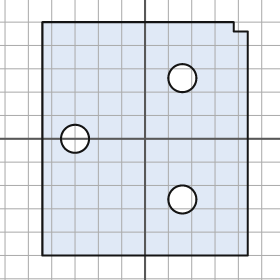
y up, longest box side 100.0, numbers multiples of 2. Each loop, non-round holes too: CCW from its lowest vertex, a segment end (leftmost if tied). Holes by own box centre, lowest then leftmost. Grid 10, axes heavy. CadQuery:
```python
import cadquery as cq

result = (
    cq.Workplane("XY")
    .moveTo(-44.0, -50.0)
    .lineTo(44.0, -50.0)
    .lineTo(44.0, 46.0)
    .lineTo(38.0, 46.0)
    .lineTo(38.0, 50.0)
    .lineTo(-44.0, 50.0)
    .close()
    .moveTo(16.0, -26.0)
    .circle(6.0)
    .moveTo(-30.0, 0.0)
    .circle(6.0)
    .moveTo(16.0, 26.0)
    .circle(6.0)
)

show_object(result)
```